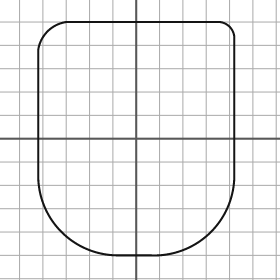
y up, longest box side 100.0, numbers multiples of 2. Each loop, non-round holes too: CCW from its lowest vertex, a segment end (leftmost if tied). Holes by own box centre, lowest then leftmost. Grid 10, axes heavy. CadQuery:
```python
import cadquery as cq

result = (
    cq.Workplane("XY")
    .moveTo(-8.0, -50.0)
    .lineTo(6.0, -50.0)
    .threePointArc((32.0, -40.0), (42.0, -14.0))
    .lineTo(42.0, 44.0)
    .threePointArc((40.0, 48.0), (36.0, 50.0))
    .lineTo(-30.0, 50.0)
    .threePointArc((-38.0, 46.0), (-42.0, 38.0))
    .lineTo(-42.0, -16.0)
    .threePointArc((-32.0, -40.0), (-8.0, -50.0))
    .close()
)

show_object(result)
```